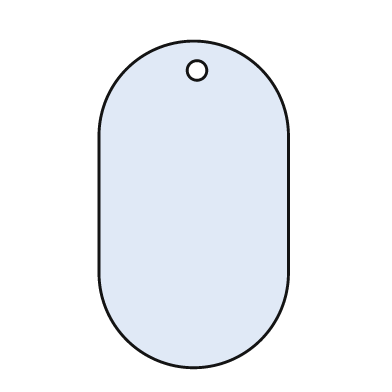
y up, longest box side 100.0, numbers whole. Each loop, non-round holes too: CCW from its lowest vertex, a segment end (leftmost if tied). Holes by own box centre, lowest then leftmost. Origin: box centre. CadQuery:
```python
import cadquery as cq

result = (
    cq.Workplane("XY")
    .moveTo(-29.0, -21.0)
    .threePointArc((0.0, -50.0), (29.0, -21.0))
    .lineTo(29.0, 21.0)
    .threePointArc((0.0, 50.0), (-29.0, 21.0))
    .close()
    .moveTo(1.0, 41.0)
    .circle(3.0)
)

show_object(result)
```